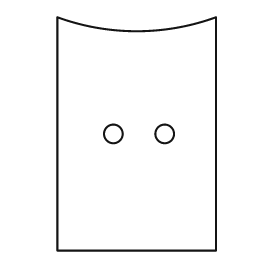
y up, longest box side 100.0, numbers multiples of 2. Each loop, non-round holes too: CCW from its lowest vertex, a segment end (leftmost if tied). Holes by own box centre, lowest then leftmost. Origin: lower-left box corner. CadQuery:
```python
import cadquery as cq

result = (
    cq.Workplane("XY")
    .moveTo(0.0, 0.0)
    .lineTo(68.0, 0.0)
    .lineTo(68.0, 100.0)
    .threePointArc((34.0, 94.0), (0.0, 100.0))
    .close()
    .moveTo(24.0, 50.0)
    .circle(4.0)
    .moveTo(46.0, 50.0)
    .circle(4.0)
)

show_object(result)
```